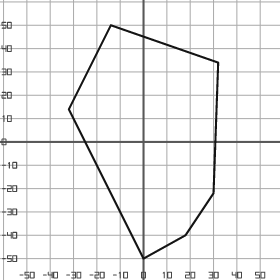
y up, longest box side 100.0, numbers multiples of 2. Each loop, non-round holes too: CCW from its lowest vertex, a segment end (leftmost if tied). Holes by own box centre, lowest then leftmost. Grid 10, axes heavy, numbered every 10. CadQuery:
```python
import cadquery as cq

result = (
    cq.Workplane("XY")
    .moveTo(0.0, -50.0)
    .lineTo(18.0, -40.0)
    .lineTo(30.0, -22.0)
    .lineTo(32.0, 34.0)
    .lineTo(-14.0, 50.0)
    .lineTo(-32.0, 14.0)
    .close()
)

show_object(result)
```